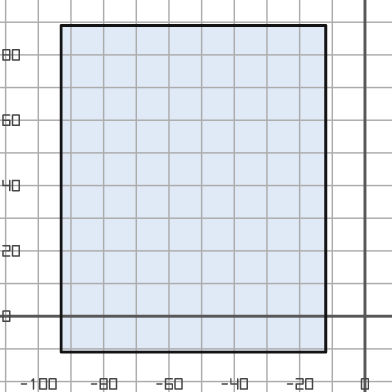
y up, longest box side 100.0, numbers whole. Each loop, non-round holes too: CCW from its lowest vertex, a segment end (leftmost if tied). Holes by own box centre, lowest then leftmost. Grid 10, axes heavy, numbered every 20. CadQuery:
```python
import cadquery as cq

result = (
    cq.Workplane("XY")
    .moveTo(-93.0, -11.0)
    .lineTo(-12.0, -11.0)
    .lineTo(-12.0, 89.0)
    .lineTo(-93.0, 89.0)
    .close()
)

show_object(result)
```